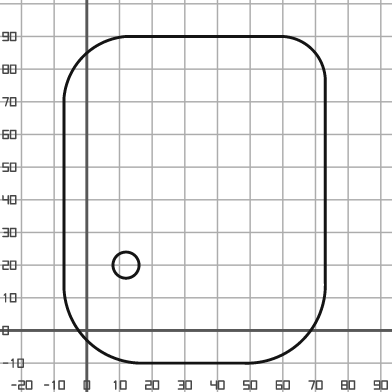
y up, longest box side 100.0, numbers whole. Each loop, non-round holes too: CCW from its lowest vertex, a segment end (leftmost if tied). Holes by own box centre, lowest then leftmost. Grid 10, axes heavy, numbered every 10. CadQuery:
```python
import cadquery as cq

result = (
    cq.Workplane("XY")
    .moveTo(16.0, -10.0)
    .lineTo(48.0, -10.0)
    .threePointArc((66.0, -3.0), (73.0, 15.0))
    .lineTo(73.0, 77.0)
    .threePointArc((69.0, 86.0), (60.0, 90.0))
    .lineTo(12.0, 90.0)
    .threePointArc((-1.0, 84.0), (-7.0, 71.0))
    .lineTo(-7.0, 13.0)
    .threePointArc((0.0, -3.0), (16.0, -10.0))
    .close()
    .moveTo(12.0, 20.0)
    .circle(4.0)
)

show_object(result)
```